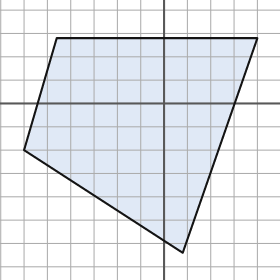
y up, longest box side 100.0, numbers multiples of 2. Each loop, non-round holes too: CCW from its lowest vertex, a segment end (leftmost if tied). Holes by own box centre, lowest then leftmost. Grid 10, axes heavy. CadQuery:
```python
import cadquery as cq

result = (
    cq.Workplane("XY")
    .moveTo(8.0, -64.0)
    .lineTo(40.0, 28.0)
    .lineTo(-46.0, 28.0)
    .lineTo(-60.0, -20.0)
    .close()
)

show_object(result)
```